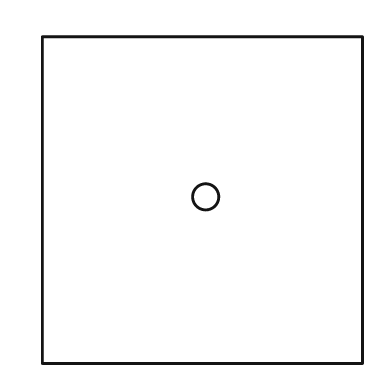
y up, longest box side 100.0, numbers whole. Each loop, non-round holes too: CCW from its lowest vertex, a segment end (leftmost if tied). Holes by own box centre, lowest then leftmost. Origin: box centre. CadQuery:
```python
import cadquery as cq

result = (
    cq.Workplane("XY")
    .moveTo(-49.0, -50.0)
    .lineTo(49.0, -50.0)
    .lineTo(49.0, 50.0)
    .lineTo(-49.0, 50.0)
    .close()
    .moveTo(1.0, 1.0)
    .circle(4.0)
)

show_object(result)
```